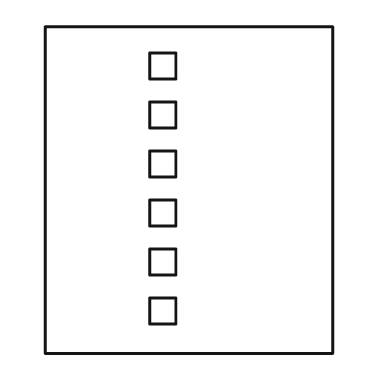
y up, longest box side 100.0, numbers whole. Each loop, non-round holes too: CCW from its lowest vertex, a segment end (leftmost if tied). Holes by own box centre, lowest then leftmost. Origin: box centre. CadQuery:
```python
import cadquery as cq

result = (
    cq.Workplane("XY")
    .moveTo(-44.0, -50.0)
    .lineTo(44.0, -50.0)
    .lineTo(44.0, 50.0)
    .lineTo(-44.0, 50.0)
    .close()
    .moveTo(-12.0, -41.0)
    .lineTo(-4.0, -41.0)
    .lineTo(-4.0, -33.0)
    .lineTo(-12.0, -33.0)
    .close()
    .moveTo(-12.0, -26.0)
    .lineTo(-4.0, -26.0)
    .lineTo(-4.0, -18.0)
    .lineTo(-12.0, -18.0)
    .close()
    .moveTo(-12.0, -11.0)
    .lineTo(-4.0, -11.0)
    .lineTo(-4.0, -3.0)
    .lineTo(-12.0, -3.0)
    .close()
    .moveTo(-12.0, 4.0)
    .lineTo(-4.0, 4.0)
    .lineTo(-4.0, 12.0)
    .lineTo(-12.0, 12.0)
    .close()
    .moveTo(-12.0, 19.0)
    .lineTo(-4.0, 19.0)
    .lineTo(-4.0, 27.0)
    .lineTo(-12.0, 27.0)
    .close()
    .moveTo(-12.0, 34.0)
    .lineTo(-4.0, 34.0)
    .lineTo(-4.0, 42.0)
    .lineTo(-12.0, 42.0)
    .close()
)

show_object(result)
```